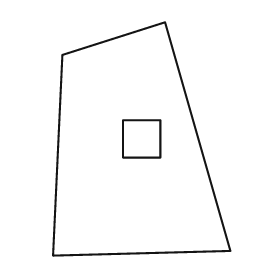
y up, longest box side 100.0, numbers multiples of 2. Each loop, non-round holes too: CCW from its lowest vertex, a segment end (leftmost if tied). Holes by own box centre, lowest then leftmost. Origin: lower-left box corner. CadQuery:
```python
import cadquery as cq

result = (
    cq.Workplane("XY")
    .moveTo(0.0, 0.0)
    .lineTo(76.0, 2.0)
    .lineTo(48.0, 100.0)
    .lineTo(4.0, 86.0)
    .close()
    .moveTo(30.0, 42.0)
    .lineTo(46.0, 42.0)
    .lineTo(46.0, 58.0)
    .lineTo(30.0, 58.0)
    .close()
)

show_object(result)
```